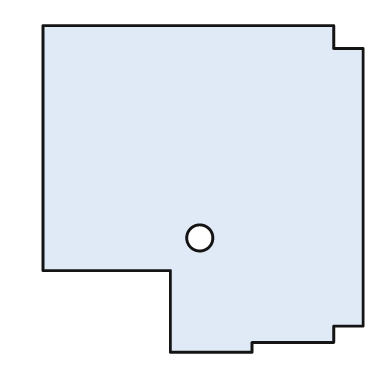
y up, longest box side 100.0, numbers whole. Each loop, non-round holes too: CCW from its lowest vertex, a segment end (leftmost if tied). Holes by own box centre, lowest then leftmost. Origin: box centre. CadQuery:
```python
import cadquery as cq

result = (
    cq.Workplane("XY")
    .moveTo(-10.0, -50.0)
    .lineTo(15.0, -50.0)
    .lineTo(15.0, -47.0)
    .lineTo(40.0, -47.0)
    .lineTo(40.0, -42.0)
    .lineTo(49.0, -42.0)
    .lineTo(49.0, 43.0)
    .lineTo(40.0, 43.0)
    .lineTo(40.0, 50.0)
    .lineTo(-49.0, 50.0)
    .lineTo(-49.0, -25.0)
    .lineTo(-10.0, -25.0)
    .close()
    .moveTo(-1.0, -15.0)
    .circle(4.0)
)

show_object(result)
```